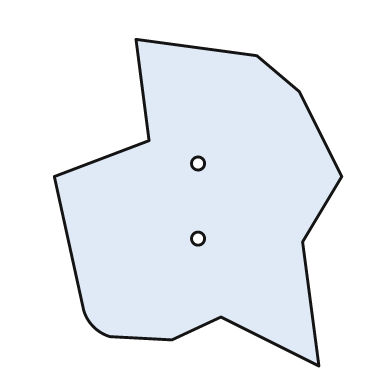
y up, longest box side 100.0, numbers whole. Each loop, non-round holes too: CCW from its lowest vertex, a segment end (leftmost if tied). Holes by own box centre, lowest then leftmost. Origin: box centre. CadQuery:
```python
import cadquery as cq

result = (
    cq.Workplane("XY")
    .moveTo(37.0, -50.0)
    .lineTo(32.0, -12.0)
    .lineTo(44.0, 8.0)
    .lineTo(31.0, 34.0)
    .lineTo(18.0, 45.0)
    .lineTo(-19.0, 50.0)
    .lineTo(-15.0, 19.0)
    .lineTo(-44.0, 8.0)
    .lineTo(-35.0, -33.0)
    .threePointArc((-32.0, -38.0), (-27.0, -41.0))
    .lineTo(-8.0, -42.0)
    .lineTo(7.0, -35.0)
    .close()
    .moveTo(0.0, -11.0)
    .circle(2.0)
    .moveTo(0.0, 12.0)
    .circle(2.0)
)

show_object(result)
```